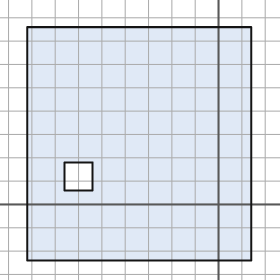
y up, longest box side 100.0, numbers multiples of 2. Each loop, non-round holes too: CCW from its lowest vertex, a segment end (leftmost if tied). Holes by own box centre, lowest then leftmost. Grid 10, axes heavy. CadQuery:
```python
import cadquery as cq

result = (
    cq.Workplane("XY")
    .moveTo(-82.0, -24.0)
    .lineTo(14.0, -24.0)
    .lineTo(14.0, 76.0)
    .lineTo(-82.0, 76.0)
    .close()
    .moveTo(-66.0, 6.0)
    .lineTo(-54.0, 6.0)
    .lineTo(-54.0, 18.0)
    .lineTo(-66.0, 18.0)
    .close()
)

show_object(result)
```